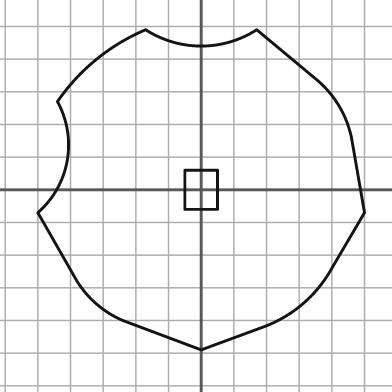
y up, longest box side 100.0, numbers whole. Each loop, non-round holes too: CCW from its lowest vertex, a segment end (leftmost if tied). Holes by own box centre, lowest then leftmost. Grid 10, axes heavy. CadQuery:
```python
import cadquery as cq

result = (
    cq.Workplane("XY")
    .moveTo(0.0, -49.0)
    .lineTo(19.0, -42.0)
    .threePointArc((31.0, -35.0), (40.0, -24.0))
    .lineTo(50.0, -7.0)
    .lineTo(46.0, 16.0)
    .threePointArc((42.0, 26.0), (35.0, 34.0))
    .lineTo(17.0, 49.0)
    .threePointArc((0.0, 44.0), (-17.0, 49.0))
    .threePointArc((-32.0, 40.0), (-44.0, 27.0))
    .threePointArc((-41.0, 9.0), (-50.0, -7.0))
    .lineTo(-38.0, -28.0)
    .threePointArc((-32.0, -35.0), (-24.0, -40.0))
    .close()
    .moveTo(-5.0, -6.0)
    .lineTo(5.0, -6.0)
    .lineTo(5.0, 6.0)
    .lineTo(-5.0, 6.0)
    .close()
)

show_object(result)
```